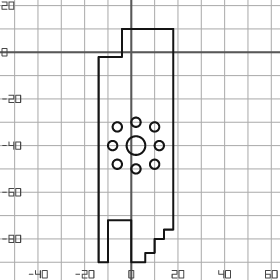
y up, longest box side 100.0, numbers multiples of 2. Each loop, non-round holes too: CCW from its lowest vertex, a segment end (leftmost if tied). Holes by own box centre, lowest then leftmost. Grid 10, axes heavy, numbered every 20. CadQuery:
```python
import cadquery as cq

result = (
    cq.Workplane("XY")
    .moveTo(-14.0, -90.0)
    .lineTo(-10.0, -90.0)
    .lineTo(-10.0, -72.0)
    .lineTo(0.0, -72.0)
    .lineTo(0.0, -90.0)
    .lineTo(6.0, -90.0)
    .lineTo(6.0, -86.0)
    .lineTo(10.0, -86.0)
    .lineTo(10.0, -80.0)
    .lineTo(14.0, -80.0)
    .lineTo(14.0, -76.0)
    .lineTo(18.0, -76.0)
    .lineTo(18.0, 10.0)
    .lineTo(-4.0, 10.0)
    .lineTo(-4.0, -2.0)
    .lineTo(-14.0, -2.0)
    .close()
    .moveTo(2.0, -50.0)
    .circle(2.0)
    .moveTo(-6.0, -48.0)
    .circle(2.0)
    .moveTo(10.0, -48.0)
    .circle(2.0)
    .moveTo(-8.0, -40.0)
    .circle(2.0)
    .moveTo(2.0, -40.0)
    .circle(4.0)
    .moveTo(12.0, -40.0)
    .circle(2.0)
    .moveTo(-6.0, -32.0)
    .circle(2.0)
    .moveTo(10.0, -32.0)
    .circle(2.0)
    .moveTo(2.0, -30.0)
    .circle(2.0)
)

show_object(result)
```